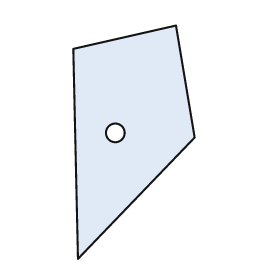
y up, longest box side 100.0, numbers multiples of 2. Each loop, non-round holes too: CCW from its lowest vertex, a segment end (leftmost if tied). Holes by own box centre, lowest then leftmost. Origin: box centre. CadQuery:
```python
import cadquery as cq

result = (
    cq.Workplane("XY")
    .moveTo(-24.0, -50.0)
    .lineTo(26.0, 2.0)
    .lineTo(18.0, 50.0)
    .lineTo(-26.0, 40.0)
    .close()
    .moveTo(-8.0, 4.0)
    .circle(4.0)
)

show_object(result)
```